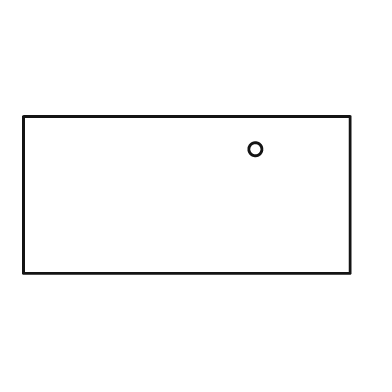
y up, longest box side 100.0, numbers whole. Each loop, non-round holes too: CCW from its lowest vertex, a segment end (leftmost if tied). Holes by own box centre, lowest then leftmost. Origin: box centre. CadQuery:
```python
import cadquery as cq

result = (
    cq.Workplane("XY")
    .moveTo(-50.0, -24.0)
    .lineTo(50.0, -24.0)
    .lineTo(50.0, 24.0)
    .lineTo(-50.0, 24.0)
    .close()
    .moveTo(21.0, 14.0)
    .circle(2.0)
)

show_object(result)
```